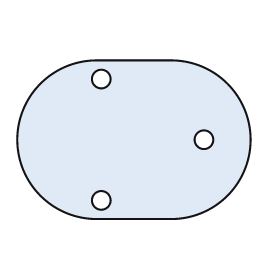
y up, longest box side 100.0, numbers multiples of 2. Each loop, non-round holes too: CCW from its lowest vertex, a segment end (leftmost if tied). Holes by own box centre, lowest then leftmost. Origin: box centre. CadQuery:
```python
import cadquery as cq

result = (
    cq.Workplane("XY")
    .moveTo(-16.0, -34.0)
    .lineTo(16.0, -34.0)
    .threePointArc((50.0, 0.0), (16.0, 34.0))
    .lineTo(-16.0, 34.0)
    .threePointArc((-50.0, 0.0), (-16.0, -34.0))
    .close()
    .moveTo(-14.0, -26.0)
    .circle(4.0)
    .moveTo(30.0, 0.0)
    .circle(4.0)
    .moveTo(-14.0, 26.0)
    .circle(4.0)
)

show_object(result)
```